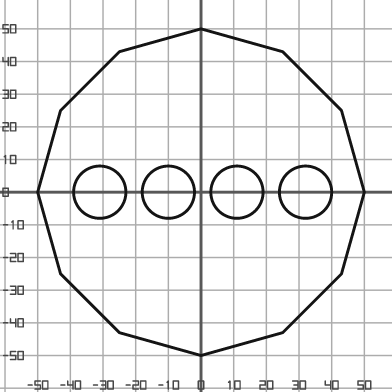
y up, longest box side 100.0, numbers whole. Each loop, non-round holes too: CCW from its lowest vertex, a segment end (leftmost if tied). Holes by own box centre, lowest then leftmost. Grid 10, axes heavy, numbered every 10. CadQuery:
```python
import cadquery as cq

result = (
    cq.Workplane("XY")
    .moveTo(0.0, -50.0)
    .lineTo(25.0, -43.0)
    .lineTo(43.0, -25.0)
    .lineTo(50.0, 0.0)
    .lineTo(43.0, 25.0)
    .lineTo(25.0, 43.0)
    .lineTo(0.0, 50.0)
    .lineTo(-25.0, 43.0)
    .lineTo(-43.0, 25.0)
    .lineTo(-50.0, 0.0)
    .lineTo(-43.0, -25.0)
    .lineTo(-25.0, -43.0)
    .close()
    .moveTo(-31.0, 0.0)
    .circle(8.0)
    .moveTo(-10.0, 0.0)
    .circle(8.0)
    .moveTo(11.0, 0.0)
    .circle(8.0)
    .moveTo(32.0, 0.0)
    .circle(8.0)
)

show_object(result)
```